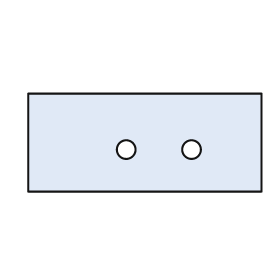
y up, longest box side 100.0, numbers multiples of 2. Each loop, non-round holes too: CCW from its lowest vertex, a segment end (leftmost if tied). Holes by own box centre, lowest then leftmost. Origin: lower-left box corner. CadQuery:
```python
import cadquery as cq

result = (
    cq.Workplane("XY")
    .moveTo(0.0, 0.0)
    .lineTo(100.0, 0.0)
    .lineTo(100.0, 42.0)
    .lineTo(0.0, 42.0)
    .close()
    .moveTo(42.0, 18.0)
    .circle(4.0)
    .moveTo(70.0, 18.0)
    .circle(4.0)
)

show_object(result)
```